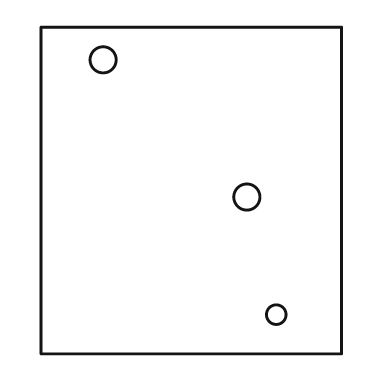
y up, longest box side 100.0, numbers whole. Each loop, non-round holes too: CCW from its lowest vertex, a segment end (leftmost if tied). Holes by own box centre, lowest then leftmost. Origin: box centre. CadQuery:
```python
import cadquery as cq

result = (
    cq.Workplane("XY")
    .moveTo(-46.0, -50.0)
    .lineTo(46.0, -50.0)
    .lineTo(46.0, 50.0)
    .lineTo(-46.0, 50.0)
    .close()
    .moveTo(26.0, -38.0)
    .circle(3.0)
    .moveTo(17.0, -2.0)
    .circle(4.0)
    .moveTo(-27.0, 40.0)
    .circle(4.0)
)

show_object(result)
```